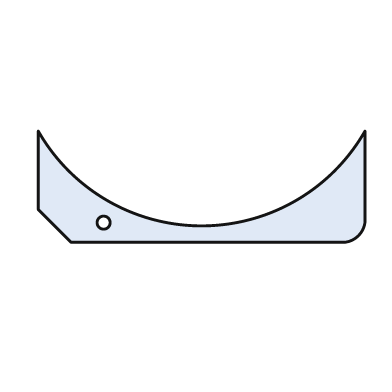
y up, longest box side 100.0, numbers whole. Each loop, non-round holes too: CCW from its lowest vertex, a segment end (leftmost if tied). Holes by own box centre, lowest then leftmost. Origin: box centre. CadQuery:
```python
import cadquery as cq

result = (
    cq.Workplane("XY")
    .moveTo(-40.0, -17.0)
    .lineTo(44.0, -17.0)
    .threePointArc((48.0, -15.0), (50.0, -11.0))
    .lineTo(50.0, 17.0)
    .threePointArc((0.0, -12.0), (-50.0, 17.0))
    .lineTo(-50.0, -7.0)
    .close()
    .moveTo(-30.0, -11.0)
    .circle(2.0)
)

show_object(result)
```